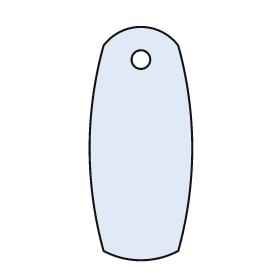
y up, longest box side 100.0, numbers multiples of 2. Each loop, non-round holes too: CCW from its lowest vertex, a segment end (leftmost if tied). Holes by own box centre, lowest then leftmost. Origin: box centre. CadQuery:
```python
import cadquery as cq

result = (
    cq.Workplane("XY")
    .moveTo(-16.0, -46.0)
    .threePointArc((0.0, -50.0), (16.0, -46.0))
    .threePointArc((22.0, -2.0), (16.0, 42.0))
    .threePointArc((0.0, 50.0), (-16.0, 42.0))
    .threePointArc((-22.0, -2.0), (-16.0, -46.0))
    .close()
    .moveTo(0.0, 36.0)
    .circle(4.0)
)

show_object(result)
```